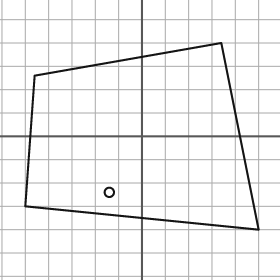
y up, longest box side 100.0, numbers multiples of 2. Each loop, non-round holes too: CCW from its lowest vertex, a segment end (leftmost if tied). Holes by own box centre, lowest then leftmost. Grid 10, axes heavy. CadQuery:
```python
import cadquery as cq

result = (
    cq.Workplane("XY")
    .moveTo(50.0, -40.0)
    .lineTo(34.0, 40.0)
    .lineTo(-46.0, 26.0)
    .lineTo(-50.0, -30.0)
    .close()
    .moveTo(-14.0, -24.0)
    .circle(2.0)
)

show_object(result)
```